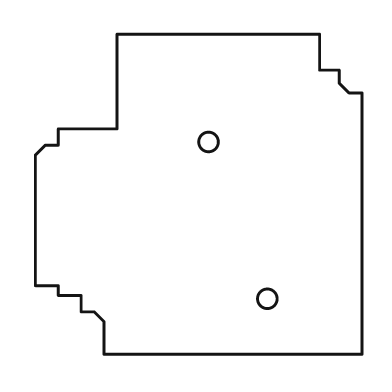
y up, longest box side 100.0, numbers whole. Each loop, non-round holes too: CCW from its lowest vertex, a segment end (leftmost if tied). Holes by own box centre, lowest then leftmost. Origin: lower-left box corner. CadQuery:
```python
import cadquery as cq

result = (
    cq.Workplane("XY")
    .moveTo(21.0, 0.0)
    .lineTo(100.0, 0.0)
    .lineTo(100.0, 80.0)
    .lineTo(96.0, 80.0)
    .lineTo(93.0, 83.0)
    .lineTo(93.0, 87.0)
    .lineTo(87.0, 87.0)
    .lineTo(87.0, 98.0)
    .lineTo(25.0, 98.0)
    .lineTo(25.0, 69.0)
    .lineTo(7.0, 69.0)
    .lineTo(7.0, 64.0)
    .lineTo(3.0, 64.0)
    .lineTo(0.0, 61.0)
    .lineTo(0.0, 21.0)
    .lineTo(7.0, 21.0)
    .lineTo(7.0, 18.0)
    .lineTo(14.0, 18.0)
    .lineTo(14.0, 13.0)
    .lineTo(18.0, 13.0)
    .lineTo(21.0, 10.0)
    .close()
    .moveTo(71.0, 17.0)
    .circle(3.0)
    .moveTo(53.0, 65.0)
    .circle(3.0)
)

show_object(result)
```